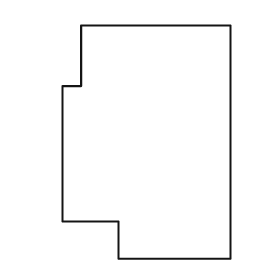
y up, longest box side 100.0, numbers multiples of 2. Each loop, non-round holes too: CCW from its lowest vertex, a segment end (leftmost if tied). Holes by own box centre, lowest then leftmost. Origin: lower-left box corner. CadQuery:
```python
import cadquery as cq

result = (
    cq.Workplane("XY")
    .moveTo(24.0, 0.0)
    .lineTo(72.0, 0.0)
    .lineTo(72.0, 100.0)
    .lineTo(8.0, 100.0)
    .lineTo(8.0, 74.0)
    .lineTo(0.0, 74.0)
    .lineTo(0.0, 16.0)
    .lineTo(24.0, 16.0)
    .close()
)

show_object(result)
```